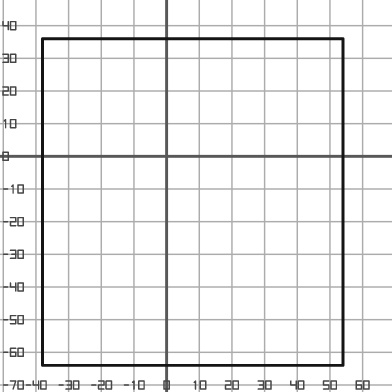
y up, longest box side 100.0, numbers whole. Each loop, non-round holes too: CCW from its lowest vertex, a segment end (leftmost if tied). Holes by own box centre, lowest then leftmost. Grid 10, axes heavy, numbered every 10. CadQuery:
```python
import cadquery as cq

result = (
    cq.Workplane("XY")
    .moveTo(-38.0, -64.0)
    .lineTo(54.0, -64.0)
    .lineTo(54.0, 36.0)
    .lineTo(-38.0, 36.0)
    .close()
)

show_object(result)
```